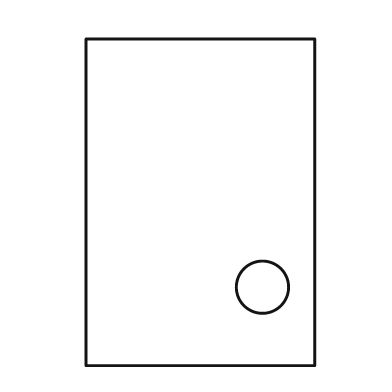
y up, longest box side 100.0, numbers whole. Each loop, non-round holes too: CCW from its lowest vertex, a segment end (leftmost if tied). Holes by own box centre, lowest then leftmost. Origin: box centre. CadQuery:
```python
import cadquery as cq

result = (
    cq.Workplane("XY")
    .moveTo(-35.0, -50.0)
    .lineTo(35.0, -50.0)
    .lineTo(35.0, 50.0)
    .lineTo(-35.0, 50.0)
    .close()
    .moveTo(19.0, -26.0)
    .circle(8.0)
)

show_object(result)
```